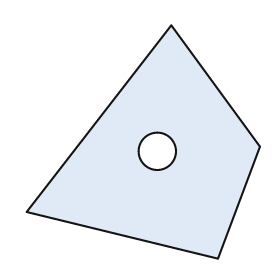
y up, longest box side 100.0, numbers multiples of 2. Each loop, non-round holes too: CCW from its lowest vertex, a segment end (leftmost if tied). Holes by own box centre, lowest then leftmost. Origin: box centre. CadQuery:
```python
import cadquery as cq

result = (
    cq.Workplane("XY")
    .moveTo(32.0, -50.0)
    .lineTo(50.0, -2.0)
    .lineTo(12.0, 50.0)
    .lineTo(-50.0, -30.0)
    .close()
    .moveTo(6.0, -4.0)
    .circle(8.0)
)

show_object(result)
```